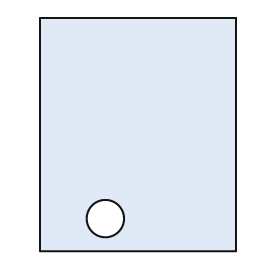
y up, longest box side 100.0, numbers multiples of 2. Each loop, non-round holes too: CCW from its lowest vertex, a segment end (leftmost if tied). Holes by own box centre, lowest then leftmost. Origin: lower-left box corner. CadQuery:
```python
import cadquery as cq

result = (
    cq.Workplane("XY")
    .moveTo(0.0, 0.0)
    .lineTo(84.0, 0.0)
    .lineTo(84.0, 100.0)
    .lineTo(0.0, 100.0)
    .close()
    .moveTo(28.0, 14.0)
    .circle(8.0)
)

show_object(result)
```